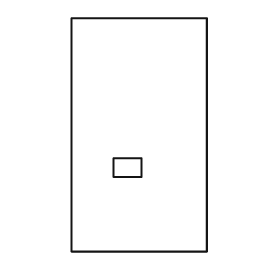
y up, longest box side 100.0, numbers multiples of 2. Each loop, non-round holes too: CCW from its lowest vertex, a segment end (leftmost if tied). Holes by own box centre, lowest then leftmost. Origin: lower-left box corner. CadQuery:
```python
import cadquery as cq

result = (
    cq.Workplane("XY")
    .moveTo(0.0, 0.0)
    .lineTo(58.0, 0.0)
    .lineTo(58.0, 100.0)
    .lineTo(0.0, 100.0)
    .close()
    .moveTo(18.0, 32.0)
    .lineTo(30.0, 32.0)
    .lineTo(30.0, 40.0)
    .lineTo(18.0, 40.0)
    .close()
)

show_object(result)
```